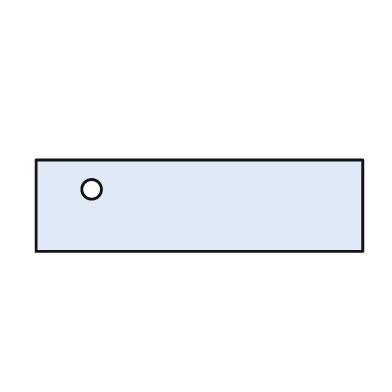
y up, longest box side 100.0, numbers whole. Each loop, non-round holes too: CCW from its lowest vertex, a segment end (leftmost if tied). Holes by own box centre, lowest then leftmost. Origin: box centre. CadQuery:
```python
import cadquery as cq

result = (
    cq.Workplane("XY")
    .moveTo(-50.0, -14.0)
    .lineTo(50.0, -14.0)
    .lineTo(50.0, 14.0)
    .lineTo(-50.0, 14.0)
    .close()
    .moveTo(-33.0, 5.0)
    .circle(3.0)
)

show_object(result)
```